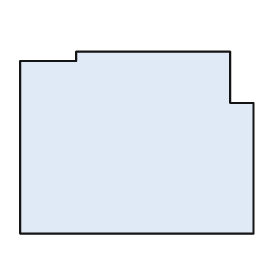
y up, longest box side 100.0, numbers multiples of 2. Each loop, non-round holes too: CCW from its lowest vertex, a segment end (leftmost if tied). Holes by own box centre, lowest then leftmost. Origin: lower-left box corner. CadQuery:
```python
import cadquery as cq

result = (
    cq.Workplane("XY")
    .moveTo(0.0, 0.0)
    .lineTo(100.0, 0.0)
    .lineTo(100.0, 56.0)
    .lineTo(90.0, 56.0)
    .lineTo(90.0, 78.0)
    .lineTo(24.0, 78.0)
    .lineTo(24.0, 74.0)
    .lineTo(0.0, 74.0)
    .close()
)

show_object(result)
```